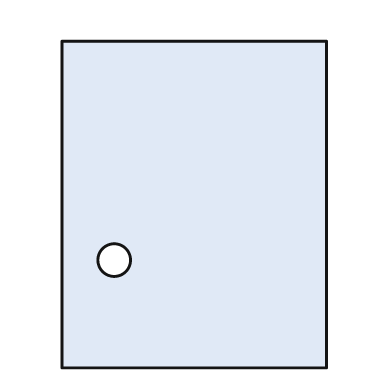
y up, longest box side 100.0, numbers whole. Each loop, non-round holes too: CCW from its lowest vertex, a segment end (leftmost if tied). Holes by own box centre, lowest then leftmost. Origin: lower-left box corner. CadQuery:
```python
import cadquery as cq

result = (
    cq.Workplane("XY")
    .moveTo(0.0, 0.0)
    .lineTo(81.0, 0.0)
    .lineTo(81.0, 100.0)
    .lineTo(0.0, 100.0)
    .close()
    .moveTo(16.0, 33.0)
    .circle(5.0)
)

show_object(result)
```